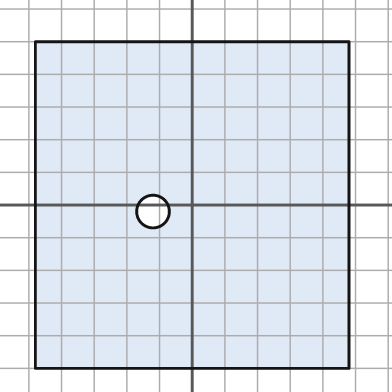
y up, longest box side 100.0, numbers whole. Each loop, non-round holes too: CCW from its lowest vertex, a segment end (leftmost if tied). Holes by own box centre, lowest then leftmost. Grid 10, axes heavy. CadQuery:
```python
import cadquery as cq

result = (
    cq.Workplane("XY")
    .moveTo(-48.0, -50.0)
    .lineTo(48.0, -50.0)
    .lineTo(48.0, 50.0)
    .lineTo(-48.0, 50.0)
    .close()
    .moveTo(-12.0, -2.0)
    .circle(5.0)
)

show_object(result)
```